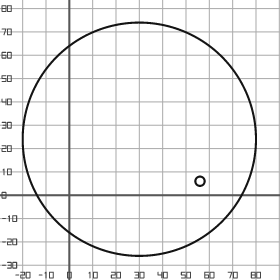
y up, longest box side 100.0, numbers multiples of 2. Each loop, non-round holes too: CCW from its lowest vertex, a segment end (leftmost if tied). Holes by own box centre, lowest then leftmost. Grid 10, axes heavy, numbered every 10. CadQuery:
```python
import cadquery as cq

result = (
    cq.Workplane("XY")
    .moveTo(30.0, 24.0)
    .circle(50.0)
    .moveTo(56.0, 6.0)
    .circle(2.0)
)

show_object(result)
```